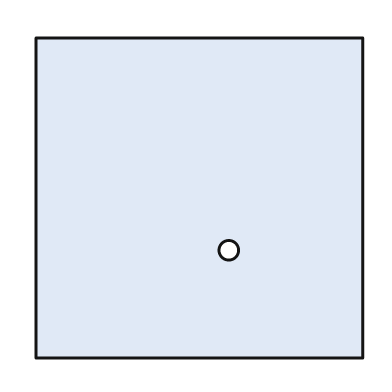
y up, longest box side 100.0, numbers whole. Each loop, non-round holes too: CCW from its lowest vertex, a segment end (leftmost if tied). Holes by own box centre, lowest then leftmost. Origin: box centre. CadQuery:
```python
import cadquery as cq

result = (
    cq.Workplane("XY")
    .moveTo(-50.0, -49.0)
    .lineTo(50.0, -49.0)
    .lineTo(50.0, 49.0)
    .lineTo(-50.0, 49.0)
    .close()
    .moveTo(9.0, -16.0)
    .circle(3.0)
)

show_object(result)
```